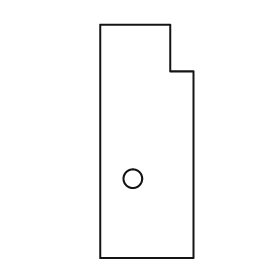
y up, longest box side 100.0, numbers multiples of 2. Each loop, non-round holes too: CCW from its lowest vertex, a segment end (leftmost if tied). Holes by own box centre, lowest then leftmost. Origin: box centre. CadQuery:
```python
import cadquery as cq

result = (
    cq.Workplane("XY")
    .moveTo(-20.0, -50.0)
    .lineTo(20.0, -50.0)
    .lineTo(20.0, 30.0)
    .lineTo(10.0, 30.0)
    .lineTo(10.0, 50.0)
    .lineTo(-20.0, 50.0)
    .close()
    .moveTo(-6.0, -16.0)
    .circle(4.0)
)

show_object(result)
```